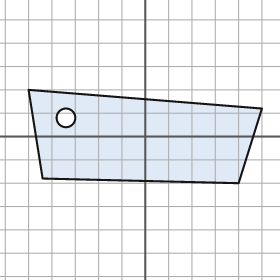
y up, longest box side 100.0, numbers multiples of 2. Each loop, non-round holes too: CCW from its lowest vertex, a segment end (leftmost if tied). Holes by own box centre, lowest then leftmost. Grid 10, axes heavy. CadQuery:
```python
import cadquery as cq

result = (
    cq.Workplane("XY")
    .moveTo(40.0, -20.0)
    .lineTo(50.0, 12.0)
    .lineTo(-50.0, 20.0)
    .lineTo(-44.0, -18.0)
    .close()
    .moveTo(-34.0, 8.0)
    .circle(4.0)
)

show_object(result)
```